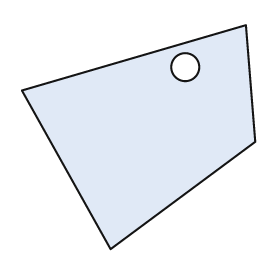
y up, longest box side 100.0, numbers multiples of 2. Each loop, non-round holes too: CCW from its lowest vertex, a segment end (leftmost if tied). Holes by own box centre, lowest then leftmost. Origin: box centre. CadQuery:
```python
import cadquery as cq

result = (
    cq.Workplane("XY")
    .moveTo(-12.0, -48.0)
    .lineTo(50.0, -2.0)
    .lineTo(46.0, 48.0)
    .lineTo(-50.0, 20.0)
    .close()
    .moveTo(20.0, 30.0)
    .circle(6.0)
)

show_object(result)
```